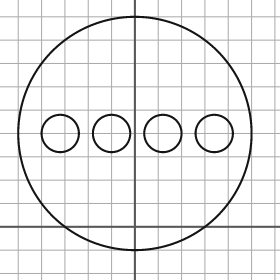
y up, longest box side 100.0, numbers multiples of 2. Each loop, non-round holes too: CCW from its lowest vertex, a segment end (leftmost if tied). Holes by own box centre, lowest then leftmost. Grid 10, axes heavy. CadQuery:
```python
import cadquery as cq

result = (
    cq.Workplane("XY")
    .moveTo(0.0, 40.0)
    .circle(50.0)
    .moveTo(-32.0, 40.0)
    .circle(8.0)
    .moveTo(-10.0, 40.0)
    .circle(8.0)
    .moveTo(12.0, 40.0)
    .circle(8.0)
    .moveTo(34.0, 40.0)
    .circle(8.0)
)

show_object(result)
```